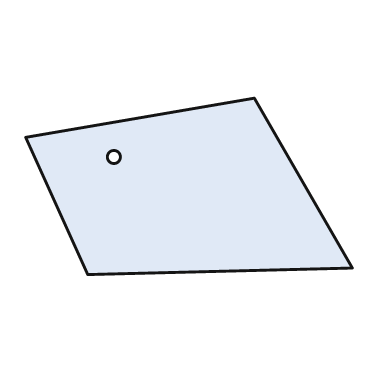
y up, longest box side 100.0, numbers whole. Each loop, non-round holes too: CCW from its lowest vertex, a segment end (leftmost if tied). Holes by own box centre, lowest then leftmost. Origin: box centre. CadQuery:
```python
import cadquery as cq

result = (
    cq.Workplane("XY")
    .moveTo(-31.0, -27.0)
    .lineTo(50.0, -25.0)
    .lineTo(20.0, 27.0)
    .lineTo(-50.0, 15.0)
    .close()
    .moveTo(-23.0, 9.0)
    .circle(2.0)
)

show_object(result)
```